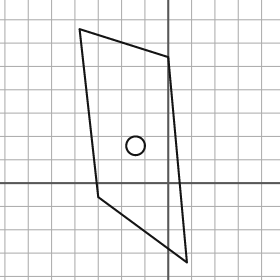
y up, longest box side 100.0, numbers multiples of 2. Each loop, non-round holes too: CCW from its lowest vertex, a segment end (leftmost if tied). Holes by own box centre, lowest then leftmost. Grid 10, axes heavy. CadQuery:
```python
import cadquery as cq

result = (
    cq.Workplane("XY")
    .moveTo(8.0, -34.0)
    .lineTo(0.0, 54.0)
    .lineTo(-38.0, 66.0)
    .lineTo(-30.0, -6.0)
    .close()
    .moveTo(-14.0, 16.0)
    .circle(4.0)
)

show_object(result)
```